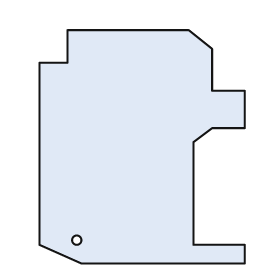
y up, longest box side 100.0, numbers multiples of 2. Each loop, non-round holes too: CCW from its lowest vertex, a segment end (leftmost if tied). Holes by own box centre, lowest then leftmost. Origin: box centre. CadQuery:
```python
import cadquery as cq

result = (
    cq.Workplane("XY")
    .moveTo(-26.0, -50.0)
    .lineTo(44.0, -50.0)
    .lineTo(44.0, -42.0)
    .lineTo(22.0, -42.0)
    .lineTo(22.0, 2.0)
    .lineTo(30.0, 8.0)
    .lineTo(44.0, 8.0)
    .lineTo(44.0, 24.0)
    .lineTo(30.0, 24.0)
    .lineTo(30.0, 42.0)
    .lineTo(20.0, 50.0)
    .lineTo(-32.0, 50.0)
    .lineTo(-32.0, 36.0)
    .lineTo(-44.0, 36.0)
    .lineTo(-44.0, -42.0)
    .close()
    .moveTo(-28.0, -40.0)
    .circle(2.0)
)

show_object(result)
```